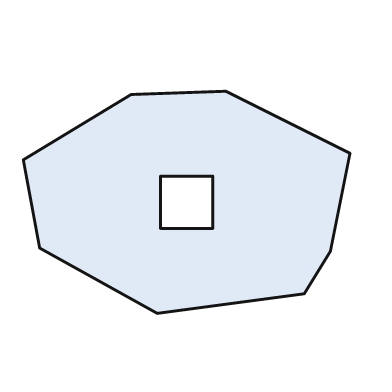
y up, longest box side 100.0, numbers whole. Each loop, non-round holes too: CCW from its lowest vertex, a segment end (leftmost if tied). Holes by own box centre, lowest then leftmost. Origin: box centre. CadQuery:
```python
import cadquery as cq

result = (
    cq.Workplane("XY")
    .moveTo(-9.0, -34.0)
    .lineTo(36.0, -28.0)
    .lineTo(44.0, -15.0)
    .lineTo(50.0, 15.0)
    .lineTo(12.0, 34.0)
    .lineTo(-17.0, 33.0)
    .lineTo(-50.0, 13.0)
    .lineTo(-45.0, -14.0)
    .close()
    .moveTo(-8.0, -8.0)
    .lineTo(8.0, -8.0)
    .lineTo(8.0, 8.0)
    .lineTo(-8.0, 8.0)
    .close()
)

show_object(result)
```